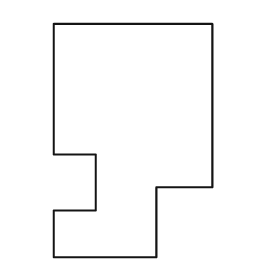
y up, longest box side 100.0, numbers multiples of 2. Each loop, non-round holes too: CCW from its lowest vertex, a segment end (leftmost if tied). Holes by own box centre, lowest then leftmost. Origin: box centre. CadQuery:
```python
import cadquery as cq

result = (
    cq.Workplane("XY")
    .moveTo(-34.0, -50.0)
    .lineTo(10.0, -50.0)
    .lineTo(10.0, -20.0)
    .lineTo(34.0, -20.0)
    .lineTo(34.0, 50.0)
    .lineTo(-34.0, 50.0)
    .lineTo(-34.0, -6.0)
    .lineTo(-16.0, -6.0)
    .lineTo(-16.0, -30.0)
    .lineTo(-34.0, -30.0)
    .close()
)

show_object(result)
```